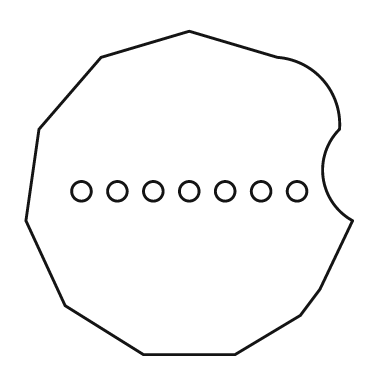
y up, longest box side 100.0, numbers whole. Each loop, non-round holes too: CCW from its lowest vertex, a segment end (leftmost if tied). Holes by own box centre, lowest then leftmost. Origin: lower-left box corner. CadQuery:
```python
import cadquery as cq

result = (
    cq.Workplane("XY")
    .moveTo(36.0, 0.0)
    .lineTo(64.0, 0.0)
    .lineTo(84.0, 12.0)
    .lineTo(90.0, 20.0)
    .lineTo(100.0, 41.0)
    .threePointArc((91.0, 54.0), (96.0, 69.0))
    .threePointArc((91.0, 84.0), (77.0, 91.0))
    .lineTo(50.0, 99.0)
    .lineTo(23.0, 91.0)
    .lineTo(4.0, 69.0)
    .lineTo(0.0, 41.0)
    .lineTo(12.0, 15.0)
    .close()
    .moveTo(17.0, 50.0)
    .circle(3.0)
    .moveTo(28.0, 50.0)
    .circle(3.0)
    .moveTo(39.0, 50.0)
    .circle(3.0)
    .moveTo(50.0, 50.0)
    .circle(3.0)
    .moveTo(61.0, 50.0)
    .circle(3.0)
    .moveTo(72.0, 50.0)
    .circle(3.0)
    .moveTo(83.0, 50.0)
    .circle(3.0)
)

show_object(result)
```